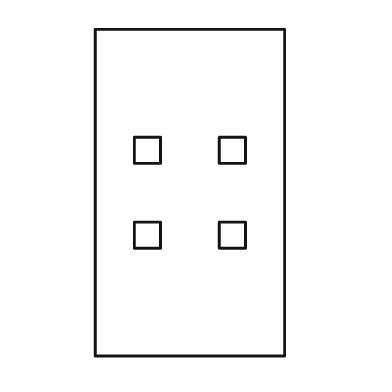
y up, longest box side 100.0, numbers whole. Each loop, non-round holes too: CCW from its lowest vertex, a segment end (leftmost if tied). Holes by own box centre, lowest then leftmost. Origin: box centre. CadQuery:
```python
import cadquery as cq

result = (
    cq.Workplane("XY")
    .moveTo(-29.0, -50.0)
    .lineTo(29.0, -50.0)
    .lineTo(29.0, 50.0)
    .lineTo(-29.0, 50.0)
    .close()
    .moveTo(-17.0, -17.0)
    .lineTo(-9.0, -17.0)
    .lineTo(-9.0, -9.0)
    .lineTo(-17.0, -9.0)
    .close()
    .moveTo(9.0, -17.0)
    .lineTo(17.0, -17.0)
    .lineTo(17.0, -9.0)
    .lineTo(9.0, -9.0)
    .close()
    .moveTo(-17.0, 9.0)
    .lineTo(-9.0, 9.0)
    .lineTo(-9.0, 17.0)
    .lineTo(-17.0, 17.0)
    .close()
    .moveTo(9.0, 9.0)
    .lineTo(17.0, 9.0)
    .lineTo(17.0, 17.0)
    .lineTo(9.0, 17.0)
    .close()
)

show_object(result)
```